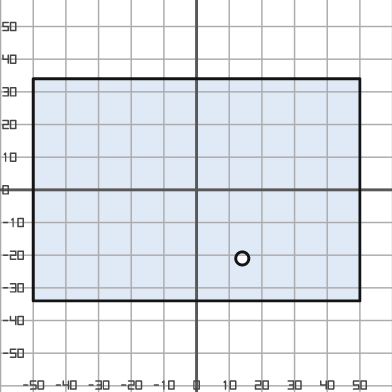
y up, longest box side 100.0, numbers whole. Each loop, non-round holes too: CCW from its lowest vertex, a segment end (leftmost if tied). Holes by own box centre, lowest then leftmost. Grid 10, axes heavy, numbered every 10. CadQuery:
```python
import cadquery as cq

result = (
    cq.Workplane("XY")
    .moveTo(-50.0, -34.0)
    .lineTo(50.0, -34.0)
    .lineTo(50.0, 34.0)
    .lineTo(-50.0, 34.0)
    .close()
    .moveTo(14.0, -21.0)
    .circle(2.0)
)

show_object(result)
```